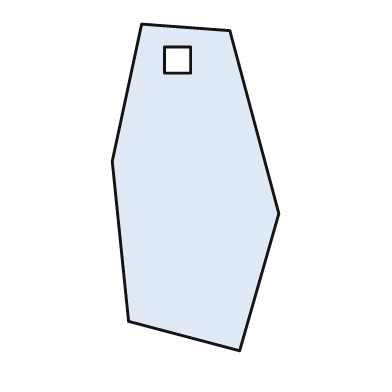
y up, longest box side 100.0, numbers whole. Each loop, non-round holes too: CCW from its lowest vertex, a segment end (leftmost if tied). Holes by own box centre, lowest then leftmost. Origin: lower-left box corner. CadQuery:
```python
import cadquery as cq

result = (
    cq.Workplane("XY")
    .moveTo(39.0, 0.0)
    .lineTo(51.0, 42.0)
    .lineTo(36.0, 98.0)
    .lineTo(9.0, 100.0)
    .lineTo(0.0, 58.0)
    .lineTo(5.0, 9.0)
    .close()
    .moveTo(16.0, 85.0)
    .lineTo(24.0, 85.0)
    .lineTo(24.0, 93.0)
    .lineTo(16.0, 93.0)
    .close()
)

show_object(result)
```